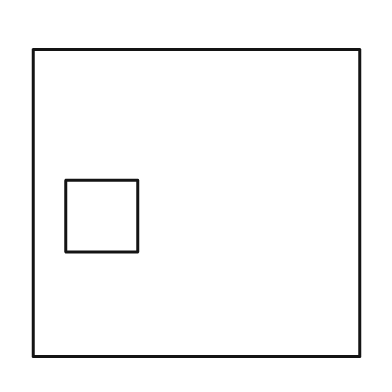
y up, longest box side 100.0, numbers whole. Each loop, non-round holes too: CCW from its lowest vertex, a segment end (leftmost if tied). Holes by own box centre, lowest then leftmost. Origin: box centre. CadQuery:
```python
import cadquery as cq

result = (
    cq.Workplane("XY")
    .moveTo(-50.0, -47.0)
    .lineTo(50.0, -47.0)
    .lineTo(50.0, 47.0)
    .lineTo(-50.0, 47.0)
    .close()
    .moveTo(-40.0, -15.0)
    .lineTo(-18.0, -15.0)
    .lineTo(-18.0, 7.0)
    .lineTo(-40.0, 7.0)
    .close()
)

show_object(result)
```